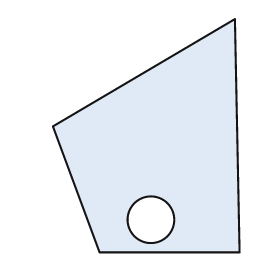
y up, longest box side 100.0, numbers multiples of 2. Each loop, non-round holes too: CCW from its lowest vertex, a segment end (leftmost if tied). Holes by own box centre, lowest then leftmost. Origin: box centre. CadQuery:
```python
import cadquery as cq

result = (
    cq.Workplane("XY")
    .moveTo(-20.0, -50.0)
    .lineTo(40.0, -50.0)
    .lineTo(38.0, 50.0)
    .lineTo(-40.0, 4.0)
    .close()
    .moveTo(2.0, -36.0)
    .circle(10.0)
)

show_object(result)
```